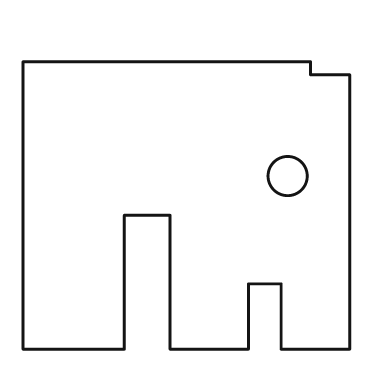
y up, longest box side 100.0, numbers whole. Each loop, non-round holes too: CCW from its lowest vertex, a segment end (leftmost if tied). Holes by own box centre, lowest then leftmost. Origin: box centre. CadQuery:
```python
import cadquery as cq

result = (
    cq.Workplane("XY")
    .moveTo(-50.0, -44.0)
    .lineTo(-19.0, -44.0)
    .lineTo(-19.0, -3.0)
    .lineTo(-5.0, -3.0)
    .lineTo(-5.0, -44.0)
    .lineTo(19.0, -44.0)
    .lineTo(19.0, -24.0)
    .lineTo(29.0, -24.0)
    .lineTo(29.0, -44.0)
    .lineTo(50.0, -44.0)
    .lineTo(50.0, 40.0)
    .lineTo(38.0, 40.0)
    .lineTo(38.0, 44.0)
    .lineTo(-50.0, 44.0)
    .close()
    .moveTo(31.0, 9.0)
    .circle(6.0)
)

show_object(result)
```